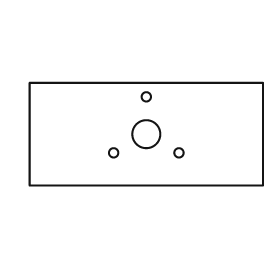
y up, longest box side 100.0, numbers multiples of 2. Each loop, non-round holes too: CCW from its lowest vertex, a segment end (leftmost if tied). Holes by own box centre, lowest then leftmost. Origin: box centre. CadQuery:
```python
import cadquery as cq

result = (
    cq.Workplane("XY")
    .moveTo(-50.0, -22.0)
    .lineTo(50.0, -22.0)
    .lineTo(50.0, 22.0)
    .lineTo(-50.0, 22.0)
    .close()
    .moveTo(-14.0, -8.0)
    .circle(2.0)
    .moveTo(14.0, -8.0)
    .circle(2.0)
    .moveTo(0.0, 0.0)
    .circle(6.0)
    .moveTo(0.0, 16.0)
    .circle(2.0)
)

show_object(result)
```